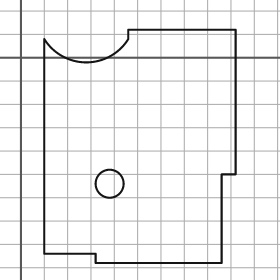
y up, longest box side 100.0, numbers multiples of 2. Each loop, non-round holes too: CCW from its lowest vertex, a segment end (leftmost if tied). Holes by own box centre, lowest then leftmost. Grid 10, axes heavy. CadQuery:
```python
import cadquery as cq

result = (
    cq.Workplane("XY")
    .moveTo(32.0, -88.0)
    .lineTo(86.0, -88.0)
    .lineTo(86.0, -50.0)
    .lineTo(92.0, -50.0)
    .lineTo(92.0, 12.0)
    .lineTo(46.0, 12.0)
    .lineTo(46.0, 8.0)
    .threePointArc((28.0, -2.0), (10.0, 8.0))
    .lineTo(10.0, -84.0)
    .lineTo(32.0, -84.0)
    .close()
    .moveTo(38.0, -54.0)
    .circle(6.0)
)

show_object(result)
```